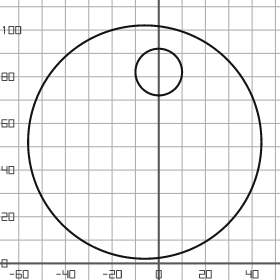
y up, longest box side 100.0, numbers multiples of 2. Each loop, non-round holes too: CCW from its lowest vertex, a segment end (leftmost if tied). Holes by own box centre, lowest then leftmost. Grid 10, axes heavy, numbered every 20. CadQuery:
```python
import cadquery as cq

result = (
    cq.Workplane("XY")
    .moveTo(-6.0, 52.0)
    .circle(50.0)
    .moveTo(0.0, 82.0)
    .circle(10.0)
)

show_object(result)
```